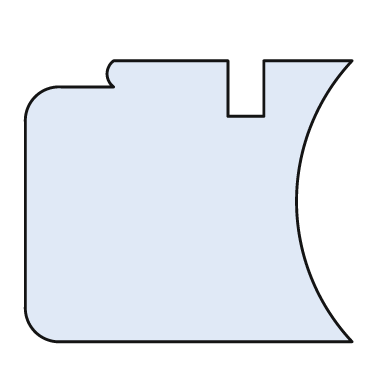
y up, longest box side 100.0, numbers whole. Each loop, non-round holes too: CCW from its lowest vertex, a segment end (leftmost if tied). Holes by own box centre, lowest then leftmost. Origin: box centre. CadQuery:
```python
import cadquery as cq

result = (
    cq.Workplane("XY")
    .moveTo(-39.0, -43.0)
    .lineTo(50.0, -43.0)
    .threePointArc((33.0, 0.0), (50.0, 43.0))
    .lineTo(23.0, 43.0)
    .lineTo(23.0, 26.0)
    .lineTo(12.0, 26.0)
    .lineTo(12.0, 43.0)
    .lineTo(-23.0, 43.0)
    .threePointArc((-25.0, 39.0), (-23.0, 35.0))
    .lineTo(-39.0, 35.0)
    .threePointArc((-47.0, 32.0), (-50.0, 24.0))
    .lineTo(-50.0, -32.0)
    .threePointArc((-47.0, -40.0), (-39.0, -43.0))
    .close()
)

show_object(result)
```